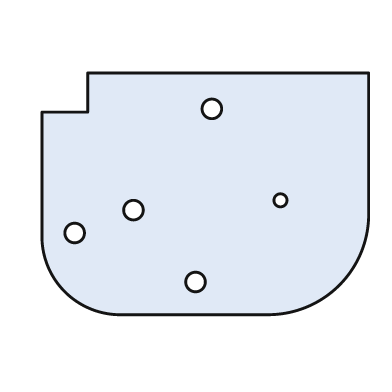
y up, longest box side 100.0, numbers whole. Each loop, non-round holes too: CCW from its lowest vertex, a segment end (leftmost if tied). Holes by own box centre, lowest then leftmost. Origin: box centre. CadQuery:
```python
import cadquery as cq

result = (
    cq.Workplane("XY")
    .moveTo(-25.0, -37.0)
    .lineTo(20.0, -37.0)
    .threePointArc((41.0, -28.0), (50.0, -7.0))
    .lineTo(50.0, 37.0)
    .lineTo(-36.0, 37.0)
    .lineTo(-36.0, 25.0)
    .lineTo(-50.0, 25.0)
    .lineTo(-50.0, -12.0)
    .threePointArc((-43.0, -30.0), (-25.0, -37.0))
    .close()
    .moveTo(-3.0, -27.0)
    .circle(3.0)
    .moveTo(-40.0, -12.0)
    .circle(3.0)
    .moveTo(-22.0, -5.0)
    .circle(3.0)
    .moveTo(23.0, -2.0)
    .circle(2.0)
    .moveTo(2.0, 26.0)
    .circle(3.0)
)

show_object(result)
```